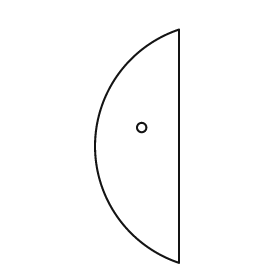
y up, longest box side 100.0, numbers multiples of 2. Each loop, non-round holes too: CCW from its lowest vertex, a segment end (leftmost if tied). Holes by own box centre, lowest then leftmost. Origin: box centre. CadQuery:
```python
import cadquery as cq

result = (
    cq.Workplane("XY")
    .moveTo(18.0, -50.0)
    .lineTo(18.0, 50.0)
    .threePointArc((-18.0, 0.0), (18.0, -50.0))
    .close()
    .moveTo(2.0, 8.0)
    .circle(2.0)
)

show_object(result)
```